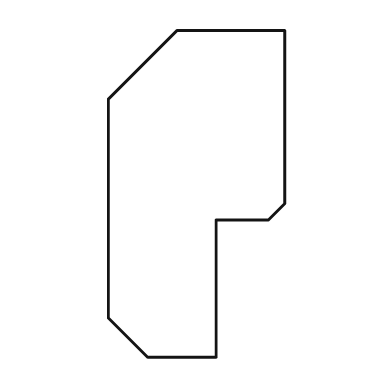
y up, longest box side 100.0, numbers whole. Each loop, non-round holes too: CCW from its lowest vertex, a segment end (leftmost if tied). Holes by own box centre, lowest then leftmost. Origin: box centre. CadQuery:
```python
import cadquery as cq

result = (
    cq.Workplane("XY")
    .moveTo(-15.0, -50.0)
    .lineTo(6.0, -50.0)
    .lineTo(6.0, -8.0)
    .lineTo(22.0, -8.0)
    .lineTo(27.0, -3.0)
    .lineTo(27.0, 50.0)
    .lineTo(-6.0, 50.0)
    .lineTo(-27.0, 29.0)
    .lineTo(-27.0, -38.0)
    .close()
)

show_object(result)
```